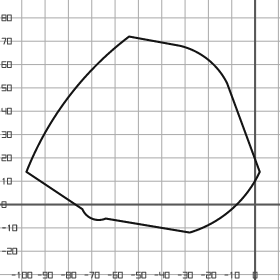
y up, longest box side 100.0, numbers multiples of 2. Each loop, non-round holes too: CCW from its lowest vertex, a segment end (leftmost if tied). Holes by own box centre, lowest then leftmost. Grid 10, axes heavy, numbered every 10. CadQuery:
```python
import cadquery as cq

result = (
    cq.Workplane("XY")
    .moveTo(-28.0, -12.0)
    .threePointArc((-10.0, -2.0), (2.0, 14.0))
    .lineTo(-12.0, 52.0)
    .threePointArc((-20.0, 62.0), (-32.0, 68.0))
    .lineTo(-54.0, 72.0)
    .threePointArc((-80.0, 46.0), (-98.0, 14.0))
    .lineTo(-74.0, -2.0)
    .threePointArc((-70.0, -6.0), (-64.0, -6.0))
    .close()
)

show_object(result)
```